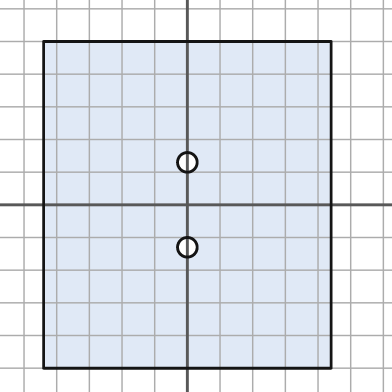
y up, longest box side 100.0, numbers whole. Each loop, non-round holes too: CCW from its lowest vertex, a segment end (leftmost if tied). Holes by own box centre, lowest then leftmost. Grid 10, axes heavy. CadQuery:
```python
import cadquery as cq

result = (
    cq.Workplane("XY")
    .moveTo(-44.0, -50.0)
    .lineTo(44.0, -50.0)
    .lineTo(44.0, 50.0)
    .lineTo(-44.0, 50.0)
    .close()
    .moveTo(0.0, -13.0)
    .circle(3.0)
    .moveTo(0.0, 13.0)
    .circle(3.0)
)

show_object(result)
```